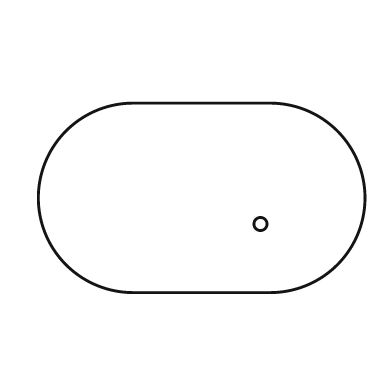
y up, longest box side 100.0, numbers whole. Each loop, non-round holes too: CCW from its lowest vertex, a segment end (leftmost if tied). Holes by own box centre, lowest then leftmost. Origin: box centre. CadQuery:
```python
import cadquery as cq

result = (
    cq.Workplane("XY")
    .moveTo(-21.0, -29.0)
    .lineTo(21.0, -29.0)
    .threePointArc((50.0, 0.0), (21.0, 29.0))
    .lineTo(-21.0, 29.0)
    .threePointArc((-50.0, 0.0), (-21.0, -29.0))
    .close()
    .moveTo(18.0, -8.0)
    .circle(2.0)
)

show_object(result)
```